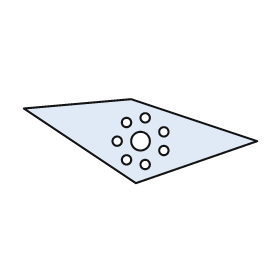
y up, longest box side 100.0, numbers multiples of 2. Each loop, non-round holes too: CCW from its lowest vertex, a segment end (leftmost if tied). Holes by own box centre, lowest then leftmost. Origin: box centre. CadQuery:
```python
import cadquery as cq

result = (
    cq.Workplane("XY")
    .moveTo(-2.0, -18.0)
    .lineTo(50.0, 0.0)
    .lineTo(-4.0, 18.0)
    .lineTo(-50.0, 14.0)
    .close()
    .moveTo(2.0, -10.0)
    .circle(2.0)
    .moveTo(-6.0, -8.0)
    .circle(2.0)
    .moveTo(10.0, -4.0)
    .circle(2.0)
    .moveTo(-10.0, 0.0)
    .circle(2.0)
    .moveTo(0.0, 0.0)
    .circle(4.0)
    .moveTo(10.0, 4.0)
    .circle(2.0)
    .moveTo(-6.0, 8.0)
    .circle(2.0)
    .moveTo(2.0, 10.0)
    .circle(2.0)
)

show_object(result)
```